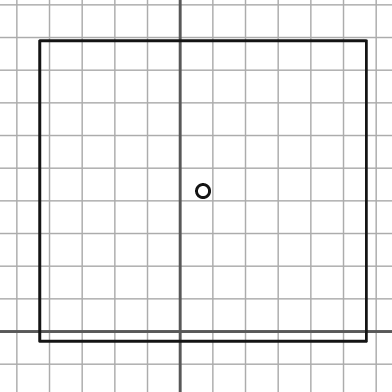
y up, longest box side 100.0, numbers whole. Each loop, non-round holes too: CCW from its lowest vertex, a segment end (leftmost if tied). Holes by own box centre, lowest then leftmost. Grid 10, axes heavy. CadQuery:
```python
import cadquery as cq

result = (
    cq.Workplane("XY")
    .moveTo(-43.0, -3.0)
    .lineTo(57.0, -3.0)
    .lineTo(57.0, 89.0)
    .lineTo(-43.0, 89.0)
    .close()
    .moveTo(7.0, 43.0)
    .circle(2.0)
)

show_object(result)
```